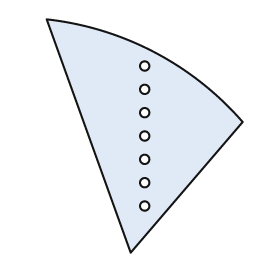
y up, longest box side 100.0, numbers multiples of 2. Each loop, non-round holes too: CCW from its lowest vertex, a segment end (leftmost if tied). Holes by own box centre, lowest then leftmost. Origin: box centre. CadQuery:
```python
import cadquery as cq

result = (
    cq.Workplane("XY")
    .moveTo(-6.0, -50.0)
    .lineTo(42.0, 6.0)
    .threePointArc((4.0, 36.0), (-42.0, 50.0))
    .close()
    .moveTo(0.0, -30.0)
    .circle(2.0)
    .moveTo(0.0, -20.0)
    .circle(2.0)
    .moveTo(0.0, -10.0)
    .circle(2.0)
    .moveTo(0.0, 0.0)
    .circle(2.0)
    .moveTo(0.0, 10.0)
    .circle(2.0)
    .moveTo(0.0, 20.0)
    .circle(2.0)
    .moveTo(0.0, 30.0)
    .circle(2.0)
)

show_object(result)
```